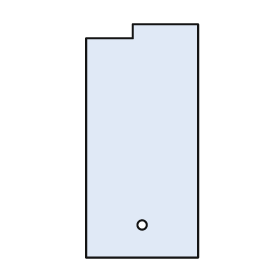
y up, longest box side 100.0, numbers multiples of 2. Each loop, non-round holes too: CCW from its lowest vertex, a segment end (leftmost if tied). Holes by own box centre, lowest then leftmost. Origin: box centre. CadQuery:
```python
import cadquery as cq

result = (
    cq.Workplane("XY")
    .moveTo(-24.0, -50.0)
    .lineTo(24.0, -50.0)
    .lineTo(24.0, 50.0)
    .lineTo(-4.0, 50.0)
    .lineTo(-4.0, 44.0)
    .lineTo(-24.0, 44.0)
    .close()
    .moveTo(0.0, -36.0)
    .circle(2.0)
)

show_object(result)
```